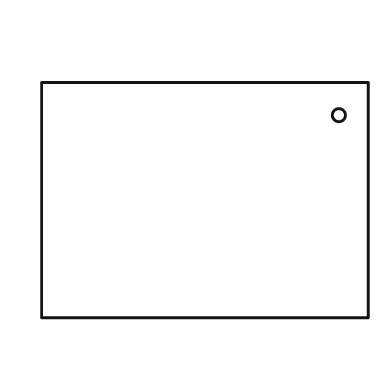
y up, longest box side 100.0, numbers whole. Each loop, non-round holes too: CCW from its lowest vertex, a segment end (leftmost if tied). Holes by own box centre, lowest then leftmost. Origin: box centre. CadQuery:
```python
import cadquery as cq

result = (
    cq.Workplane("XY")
    .moveTo(-50.0, -36.0)
    .lineTo(50.0, -36.0)
    .lineTo(50.0, 36.0)
    .lineTo(-50.0, 36.0)
    .close()
    .moveTo(41.0, 26.0)
    .circle(2.0)
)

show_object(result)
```